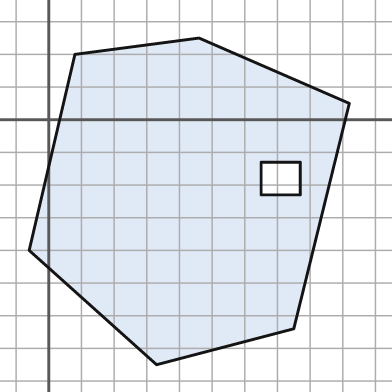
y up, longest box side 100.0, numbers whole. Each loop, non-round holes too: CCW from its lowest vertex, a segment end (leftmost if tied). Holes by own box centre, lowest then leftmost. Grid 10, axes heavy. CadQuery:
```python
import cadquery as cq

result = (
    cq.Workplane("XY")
    .moveTo(33.0, -75.0)
    .lineTo(75.0, -64.0)
    .lineTo(92.0, 5.0)
    .lineTo(46.0, 25.0)
    .lineTo(8.0, 20.0)
    .lineTo(-6.0, -40.0)
    .close()
    .moveTo(65.0, -23.0)
    .lineTo(77.0, -23.0)
    .lineTo(77.0, -13.0)
    .lineTo(65.0, -13.0)
    .close()
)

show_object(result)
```